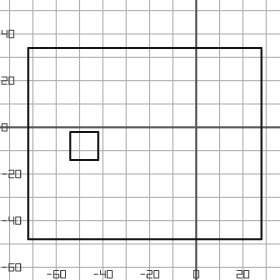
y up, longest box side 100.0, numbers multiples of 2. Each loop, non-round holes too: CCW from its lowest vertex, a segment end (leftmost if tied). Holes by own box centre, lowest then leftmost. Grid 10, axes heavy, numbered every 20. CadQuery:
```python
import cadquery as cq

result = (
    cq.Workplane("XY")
    .moveTo(-72.0, -48.0)
    .lineTo(28.0, -48.0)
    .lineTo(28.0, 34.0)
    .lineTo(-72.0, 34.0)
    .close()
    .moveTo(-54.0, -14.0)
    .lineTo(-42.0, -14.0)
    .lineTo(-42.0, -2.0)
    .lineTo(-54.0, -2.0)
    .close()
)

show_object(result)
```